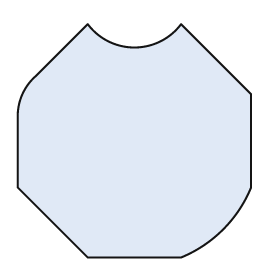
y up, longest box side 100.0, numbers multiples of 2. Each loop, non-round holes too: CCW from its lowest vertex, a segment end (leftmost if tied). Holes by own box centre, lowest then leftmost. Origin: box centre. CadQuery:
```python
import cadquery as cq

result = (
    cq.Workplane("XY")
    .moveTo(-20.0, -50.0)
    .lineTo(20.0, -50.0)
    .threePointArc((38.0, -38.0), (50.0, -20.0))
    .lineTo(50.0, 20.0)
    .lineTo(20.0, 50.0)
    .threePointArc((0.0, 40.0), (-20.0, 50.0))
    .lineTo(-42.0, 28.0)
    .threePointArc((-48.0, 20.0), (-50.0, 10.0))
    .lineTo(-50.0, -20.0)
    .close()
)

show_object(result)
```